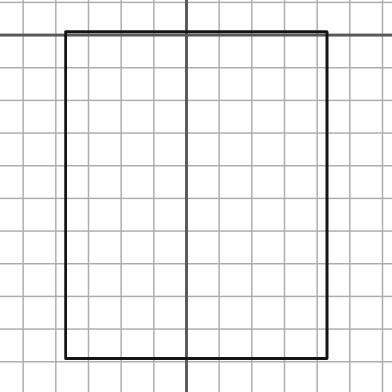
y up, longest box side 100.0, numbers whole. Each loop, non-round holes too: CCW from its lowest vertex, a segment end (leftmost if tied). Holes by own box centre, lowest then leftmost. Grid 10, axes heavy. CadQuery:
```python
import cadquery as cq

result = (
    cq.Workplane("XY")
    .moveTo(-37.0, -99.0)
    .lineTo(43.0, -99.0)
    .lineTo(43.0, 1.0)
    .lineTo(-37.0, 1.0)
    .close()
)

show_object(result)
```